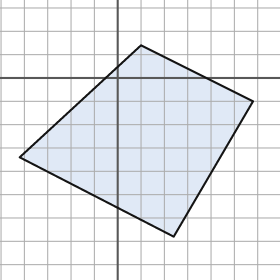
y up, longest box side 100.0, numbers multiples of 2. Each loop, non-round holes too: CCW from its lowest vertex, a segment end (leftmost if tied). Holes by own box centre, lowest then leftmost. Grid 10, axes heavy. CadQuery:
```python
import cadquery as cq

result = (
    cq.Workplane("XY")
    .moveTo(24.0, -68.0)
    .lineTo(58.0, -10.0)
    .lineTo(10.0, 14.0)
    .lineTo(-42.0, -34.0)
    .close()
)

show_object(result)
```